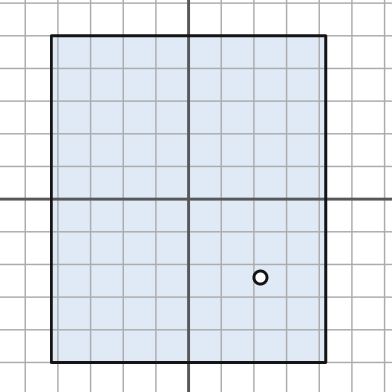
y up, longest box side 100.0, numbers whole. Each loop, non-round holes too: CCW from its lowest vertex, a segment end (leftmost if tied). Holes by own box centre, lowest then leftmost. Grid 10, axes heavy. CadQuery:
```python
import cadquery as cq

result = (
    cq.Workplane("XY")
    .moveTo(-42.0, -50.0)
    .lineTo(42.0, -50.0)
    .lineTo(42.0, 50.0)
    .lineTo(-42.0, 50.0)
    .close()
    .moveTo(22.0, -24.0)
    .circle(2.0)
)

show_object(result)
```